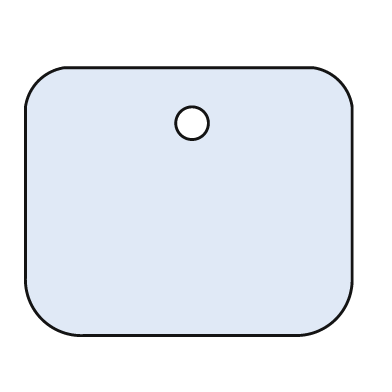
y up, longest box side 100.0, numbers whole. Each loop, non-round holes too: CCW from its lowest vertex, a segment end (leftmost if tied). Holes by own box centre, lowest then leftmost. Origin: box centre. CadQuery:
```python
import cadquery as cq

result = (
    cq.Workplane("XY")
    .moveTo(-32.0, -41.0)
    .lineTo(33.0, -41.0)
    .threePointArc((45.0, -36.0), (50.0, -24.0))
    .lineTo(50.0, 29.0)
    .threePointArc((46.0, 37.0), (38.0, 41.0))
    .lineTo(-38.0, 41.0)
    .threePointArc((-46.0, 37.0), (-50.0, 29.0))
    .lineTo(-50.0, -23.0)
    .threePointArc((-45.0, -36.0), (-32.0, -41.0))
    .close()
    .moveTo(1.0, 24.0)
    .circle(5.0)
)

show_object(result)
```